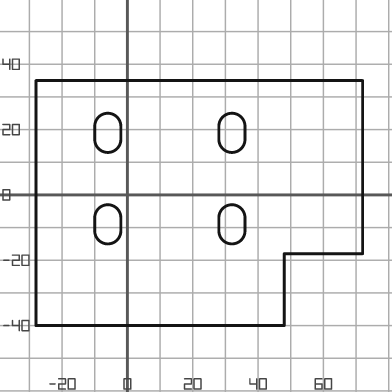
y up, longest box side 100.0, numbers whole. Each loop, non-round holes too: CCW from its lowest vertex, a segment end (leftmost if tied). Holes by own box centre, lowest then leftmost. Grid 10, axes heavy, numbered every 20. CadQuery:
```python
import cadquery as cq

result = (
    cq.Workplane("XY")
    .moveTo(-28.0, -40.0)
    .lineTo(48.0, -40.0)
    .lineTo(48.0, -18.0)
    .lineTo(72.0, -18.0)
    .lineTo(72.0, 35.0)
    .lineTo(-28.0, 35.0)
    .close()
    .moveTo(-10.0, -11.0)
    .threePointArc((-6.0, -15.0), (-2.0, -11.0))
    .lineTo(-2.0, -7.0)
    .threePointArc((-6.0, -3.0), (-10.0, -7.0))
    .close()
    .moveTo(28.0, -11.0)
    .threePointArc((32.0, -15.0), (36.0, -11.0))
    .lineTo(36.0, -7.0)
    .threePointArc((32.0, -3.0), (28.0, -7.0))
    .close()
    .moveTo(-10.0, 17.0)
    .threePointArc((-6.0, 13.0), (-2.0, 17.0))
    .lineTo(-2.0, 21.0)
    .threePointArc((-6.0, 25.0), (-10.0, 21.0))
    .close()
    .moveTo(28.0, 17.0)
    .threePointArc((32.0, 13.0), (36.0, 17.0))
    .lineTo(36.0, 21.0)
    .threePointArc((32.0, 25.0), (28.0, 21.0))
    .close()
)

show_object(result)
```